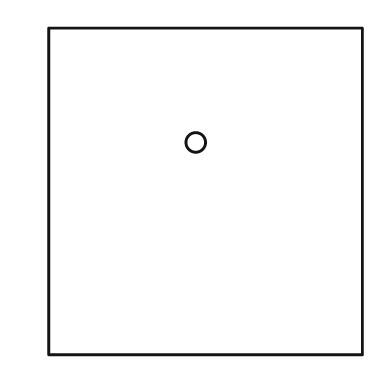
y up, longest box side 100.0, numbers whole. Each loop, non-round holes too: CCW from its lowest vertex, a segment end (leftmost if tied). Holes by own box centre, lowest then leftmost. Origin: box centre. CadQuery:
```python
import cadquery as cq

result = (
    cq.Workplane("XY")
    .moveTo(-48.0, -50.0)
    .lineTo(48.0, -50.0)
    .lineTo(48.0, 50.0)
    .lineTo(-48.0, 50.0)
    .close()
    .moveTo(-3.0, 15.0)
    .circle(3.0)
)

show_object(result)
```